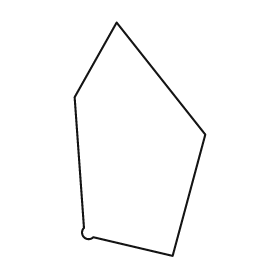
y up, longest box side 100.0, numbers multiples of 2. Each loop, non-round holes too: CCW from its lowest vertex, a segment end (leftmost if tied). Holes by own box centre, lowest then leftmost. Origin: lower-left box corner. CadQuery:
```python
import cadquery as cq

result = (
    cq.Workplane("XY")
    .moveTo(42.0, 0.0)
    .lineTo(56.0, 52.0)
    .lineTo(18.0, 100.0)
    .lineTo(0.0, 68.0)
    .lineTo(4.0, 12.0)
    .threePointArc((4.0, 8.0), (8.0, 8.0))
    .close()
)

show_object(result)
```